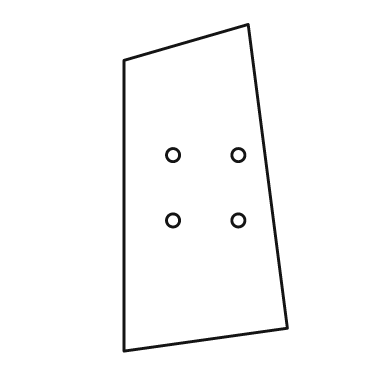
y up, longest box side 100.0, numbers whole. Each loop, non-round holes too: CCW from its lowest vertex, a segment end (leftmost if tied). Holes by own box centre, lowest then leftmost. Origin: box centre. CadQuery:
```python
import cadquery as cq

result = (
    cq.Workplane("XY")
    .moveTo(-25.0, -50.0)
    .lineTo(25.0, -43.0)
    .lineTo(13.0, 50.0)
    .lineTo(-25.0, 39.0)
    .close()
    .moveTo(-10.0, -10.0)
    .circle(2.0)
    .moveTo(10.0, -10.0)
    .circle(2.0)
    .moveTo(-10.0, 10.0)
    .circle(2.0)
    .moveTo(10.0, 10.0)
    .circle(2.0)
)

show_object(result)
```